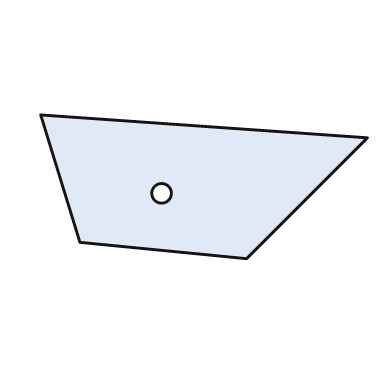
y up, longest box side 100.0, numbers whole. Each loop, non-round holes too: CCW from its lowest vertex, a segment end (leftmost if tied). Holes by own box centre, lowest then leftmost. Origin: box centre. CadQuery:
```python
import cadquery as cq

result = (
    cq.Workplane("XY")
    .moveTo(13.0, -22.0)
    .lineTo(50.0, 15.0)
    .lineTo(-50.0, 22.0)
    .lineTo(-38.0, -17.0)
    .close()
    .moveTo(-13.0, -2.0)
    .circle(3.0)
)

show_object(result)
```